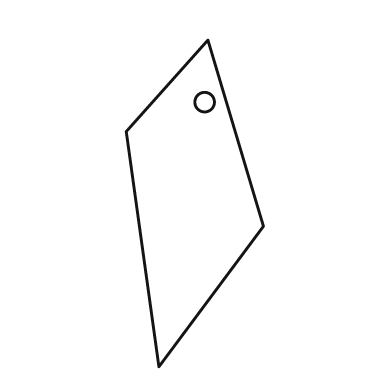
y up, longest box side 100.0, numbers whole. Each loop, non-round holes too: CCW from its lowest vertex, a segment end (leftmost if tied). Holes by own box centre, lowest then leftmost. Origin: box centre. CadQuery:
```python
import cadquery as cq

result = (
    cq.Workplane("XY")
    .moveTo(-11.0, -50.0)
    .lineTo(21.0, -7.0)
    .lineTo(4.0, 50.0)
    .lineTo(-21.0, 22.0)
    .close()
    .moveTo(3.0, 31.0)
    .circle(3.0)
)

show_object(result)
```